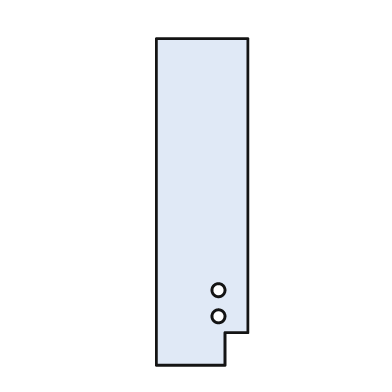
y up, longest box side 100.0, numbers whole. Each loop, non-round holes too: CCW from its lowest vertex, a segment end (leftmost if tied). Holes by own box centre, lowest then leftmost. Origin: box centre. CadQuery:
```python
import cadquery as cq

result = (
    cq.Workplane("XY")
    .moveTo(-14.0, -50.0)
    .lineTo(7.0, -50.0)
    .lineTo(7.0, -40.0)
    .lineTo(14.0, -40.0)
    .lineTo(14.0, 50.0)
    .lineTo(-14.0, 50.0)
    .close()
    .moveTo(5.0, -35.0)
    .circle(2.0)
    .moveTo(5.0, -27.0)
    .circle(2.0)
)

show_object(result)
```